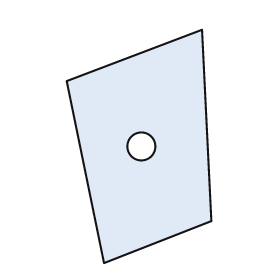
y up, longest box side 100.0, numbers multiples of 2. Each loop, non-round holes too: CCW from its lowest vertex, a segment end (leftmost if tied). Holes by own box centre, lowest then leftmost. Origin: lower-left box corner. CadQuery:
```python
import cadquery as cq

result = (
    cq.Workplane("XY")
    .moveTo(16.0, 0.0)
    .lineTo(62.0, 18.0)
    .lineTo(58.0, 100.0)
    .lineTo(0.0, 78.0)
    .close()
    .moveTo(32.0, 50.0)
    .circle(6.0)
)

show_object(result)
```